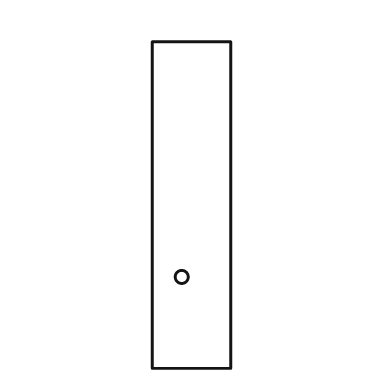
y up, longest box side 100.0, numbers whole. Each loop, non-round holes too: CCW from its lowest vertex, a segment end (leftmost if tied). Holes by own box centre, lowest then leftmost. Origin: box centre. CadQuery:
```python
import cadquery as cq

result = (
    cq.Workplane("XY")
    .moveTo(-12.0, -50.0)
    .lineTo(12.0, -50.0)
    .lineTo(12.0, 50.0)
    .lineTo(-12.0, 50.0)
    .close()
    .moveTo(-3.0, -22.0)
    .circle(2.0)
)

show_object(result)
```